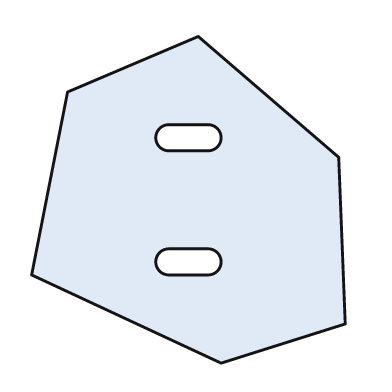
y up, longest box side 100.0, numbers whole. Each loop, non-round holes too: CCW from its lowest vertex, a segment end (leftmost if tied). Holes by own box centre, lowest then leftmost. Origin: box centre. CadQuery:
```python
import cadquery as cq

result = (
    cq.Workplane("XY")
    .moveTo(10.0, -50.0)
    .lineTo(48.0, -38.0)
    .lineTo(46.0, 13.0)
    .lineTo(3.0, 50.0)
    .lineTo(-37.0, 33.0)
    .lineTo(-48.0, -23.0)
    .close()
    .moveTo(-6.0, -23.0)
    .lineTo(6.0, -23.0)
    .threePointArc((10.0, -19.0), (6.0, -15.0))
    .lineTo(-6.0, -15.0)
    .threePointArc((-10.0, -19.0), (-6.0, -23.0))
    .close()
    .moveTo(-6.0, 15.0)
    .lineTo(6.0, 15.0)
    .threePointArc((10.0, 19.0), (6.0, 23.0))
    .lineTo(-6.0, 23.0)
    .threePointArc((-10.0, 19.0), (-6.0, 15.0))
    .close()
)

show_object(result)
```